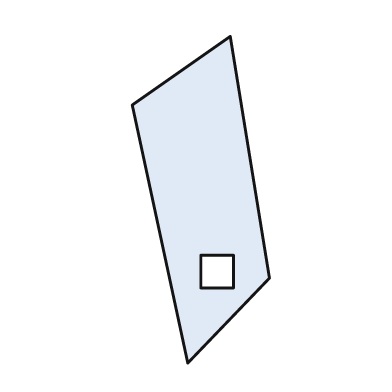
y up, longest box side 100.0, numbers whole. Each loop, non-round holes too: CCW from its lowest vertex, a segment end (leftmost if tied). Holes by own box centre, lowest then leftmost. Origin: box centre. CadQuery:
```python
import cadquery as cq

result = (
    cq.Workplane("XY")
    .moveTo(-4.0, -50.0)
    .lineTo(21.0, -24.0)
    .lineTo(9.0, 50.0)
    .lineTo(-21.0, 29.0)
    .close()
    .moveTo(0.0, -27.0)
    .lineTo(10.0, -27.0)
    .lineTo(10.0, -17.0)
    .lineTo(0.0, -17.0)
    .close()
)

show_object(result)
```